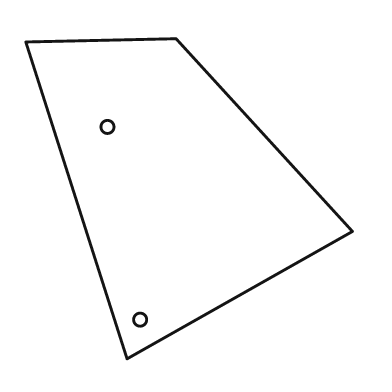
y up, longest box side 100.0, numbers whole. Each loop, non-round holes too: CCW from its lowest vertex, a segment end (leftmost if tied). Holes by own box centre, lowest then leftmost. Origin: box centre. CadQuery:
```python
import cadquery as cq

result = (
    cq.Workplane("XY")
    .moveTo(-19.0, -49.0)
    .lineTo(50.0, -10.0)
    .lineTo(-4.0, 49.0)
    .lineTo(-50.0, 48.0)
    .close()
    .moveTo(-15.0, -37.0)
    .circle(2.0)
    .moveTo(-25.0, 22.0)
    .circle(2.0)
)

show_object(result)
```